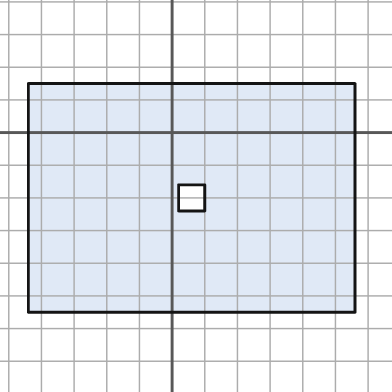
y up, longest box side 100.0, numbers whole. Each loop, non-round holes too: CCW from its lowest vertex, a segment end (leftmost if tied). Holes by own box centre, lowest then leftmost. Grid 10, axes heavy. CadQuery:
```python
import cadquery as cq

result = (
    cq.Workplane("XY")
    .moveTo(-44.0, -55.0)
    .lineTo(56.0, -55.0)
    .lineTo(56.0, 15.0)
    .lineTo(-44.0, 15.0)
    .close()
    .moveTo(2.0, -24.0)
    .lineTo(10.0, -24.0)
    .lineTo(10.0, -16.0)
    .lineTo(2.0, -16.0)
    .close()
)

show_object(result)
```